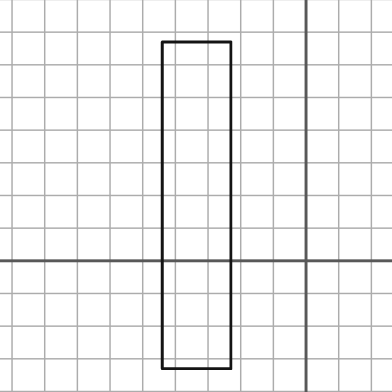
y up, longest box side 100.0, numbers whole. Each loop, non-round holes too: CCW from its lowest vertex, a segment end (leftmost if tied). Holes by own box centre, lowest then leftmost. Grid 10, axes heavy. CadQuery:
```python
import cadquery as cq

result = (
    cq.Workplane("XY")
    .moveTo(-44.0, -33.0)
    .lineTo(-23.0, -33.0)
    .lineTo(-23.0, 67.0)
    .lineTo(-44.0, 67.0)
    .close()
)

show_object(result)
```